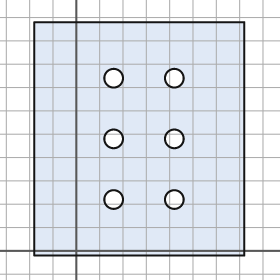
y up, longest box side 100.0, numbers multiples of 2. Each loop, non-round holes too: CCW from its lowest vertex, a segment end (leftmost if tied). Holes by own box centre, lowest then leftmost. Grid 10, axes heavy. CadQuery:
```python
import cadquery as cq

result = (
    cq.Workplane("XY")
    .moveTo(-18.0, -2.0)
    .lineTo(72.0, -2.0)
    .lineTo(72.0, 98.0)
    .lineTo(-18.0, 98.0)
    .close()
    .moveTo(16.0, 22.0)
    .circle(4.0)
    .moveTo(42.0, 22.0)
    .circle(4.0)
    .moveTo(16.0, 48.0)
    .circle(4.0)
    .moveTo(42.0, 48.0)
    .circle(4.0)
    .moveTo(16.0, 74.0)
    .circle(4.0)
    .moveTo(42.0, 74.0)
    .circle(4.0)
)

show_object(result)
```